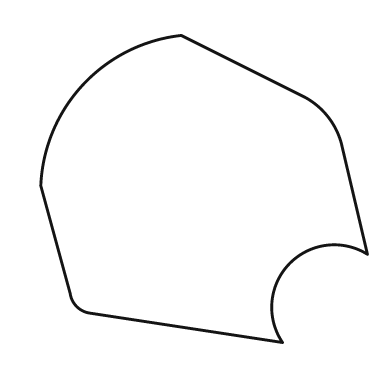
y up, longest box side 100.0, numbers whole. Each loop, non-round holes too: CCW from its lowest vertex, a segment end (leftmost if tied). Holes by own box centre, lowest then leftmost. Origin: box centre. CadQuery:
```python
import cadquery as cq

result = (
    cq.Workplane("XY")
    .moveTo(24.0, -47.0)
    .threePointArc((26.0, -23.0), (50.0, -20.0))
    .lineTo(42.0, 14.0)
    .threePointArc((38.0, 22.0), (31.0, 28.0))
    .lineTo(-7.0, 47.0)
    .threePointArc((-37.0, 32.0), (-50.0, 1.0))
    .lineTo(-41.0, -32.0)
    .threePointArc((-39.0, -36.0), (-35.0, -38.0))
    .close()
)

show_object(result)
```